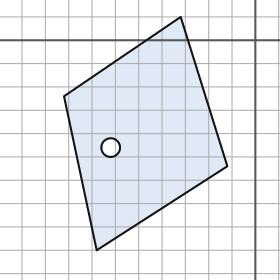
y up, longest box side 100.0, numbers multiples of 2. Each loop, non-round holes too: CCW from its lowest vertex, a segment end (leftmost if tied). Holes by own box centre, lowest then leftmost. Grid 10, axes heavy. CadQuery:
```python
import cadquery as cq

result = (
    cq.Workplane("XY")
    .moveTo(-68.0, -90.0)
    .lineTo(-12.0, -54.0)
    .lineTo(-32.0, 10.0)
    .lineTo(-82.0, -24.0)
    .close()
    .moveTo(-62.0, -46.0)
    .circle(4.0)
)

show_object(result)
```